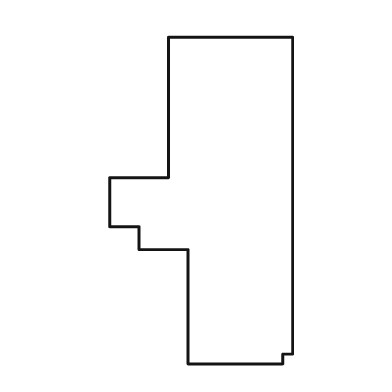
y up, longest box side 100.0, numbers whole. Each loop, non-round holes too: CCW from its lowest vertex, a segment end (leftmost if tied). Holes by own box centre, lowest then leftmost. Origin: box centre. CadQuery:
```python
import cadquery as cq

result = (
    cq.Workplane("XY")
    .moveTo(-4.0, -50.0)
    .lineTo(25.0, -50.0)
    .lineTo(25.0, -47.0)
    .lineTo(28.0, -47.0)
    .lineTo(28.0, 50.0)
    .lineTo(-10.0, 50.0)
    .lineTo(-10.0, 7.0)
    .lineTo(-28.0, 7.0)
    .lineTo(-28.0, -8.0)
    .lineTo(-19.0, -8.0)
    .lineTo(-19.0, -15.0)
    .lineTo(-4.0, -15.0)
    .close()
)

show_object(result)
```